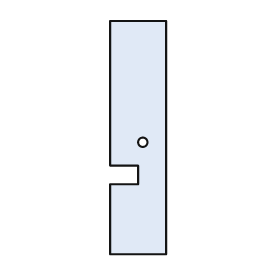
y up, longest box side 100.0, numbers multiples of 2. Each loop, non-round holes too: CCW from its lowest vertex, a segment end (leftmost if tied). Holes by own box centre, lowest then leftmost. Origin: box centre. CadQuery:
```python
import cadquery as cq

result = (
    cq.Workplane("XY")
    .moveTo(-12.0, -50.0)
    .lineTo(12.0, -50.0)
    .lineTo(12.0, 50.0)
    .lineTo(-12.0, 50.0)
    .lineTo(-12.0, -12.0)
    .lineTo(0.0, -12.0)
    .lineTo(0.0, -20.0)
    .lineTo(-12.0, -20.0)
    .close()
    .moveTo(2.0, -2.0)
    .circle(2.0)
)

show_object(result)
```